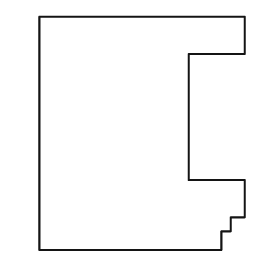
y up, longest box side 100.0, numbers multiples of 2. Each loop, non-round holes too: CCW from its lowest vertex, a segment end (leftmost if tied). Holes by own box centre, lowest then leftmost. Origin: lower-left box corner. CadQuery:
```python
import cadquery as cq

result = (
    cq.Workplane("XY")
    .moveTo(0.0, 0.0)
    .lineTo(78.0, 0.0)
    .lineTo(78.0, 8.0)
    .lineTo(82.0, 8.0)
    .lineTo(82.0, 14.0)
    .lineTo(88.0, 14.0)
    .lineTo(88.0, 30.0)
    .lineTo(64.0, 30.0)
    .lineTo(64.0, 84.0)
    .lineTo(88.0, 84.0)
    .lineTo(88.0, 100.0)
    .lineTo(0.0, 100.0)
    .close()
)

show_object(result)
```